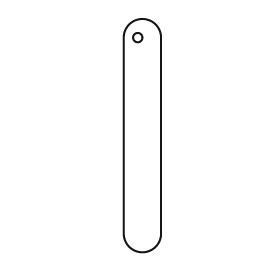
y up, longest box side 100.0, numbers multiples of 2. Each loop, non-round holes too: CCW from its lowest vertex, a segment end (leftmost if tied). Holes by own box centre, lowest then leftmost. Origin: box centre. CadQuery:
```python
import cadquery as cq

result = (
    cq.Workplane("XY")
    .moveTo(-8.0, -42.0)
    .threePointArc((0.0, -50.0), (8.0, -42.0))
    .lineTo(8.0, 42.0)
    .threePointArc((0.0, 50.0), (-8.0, 42.0))
    .close()
    .moveTo(-2.0, 42.0)
    .circle(2.0)
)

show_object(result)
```